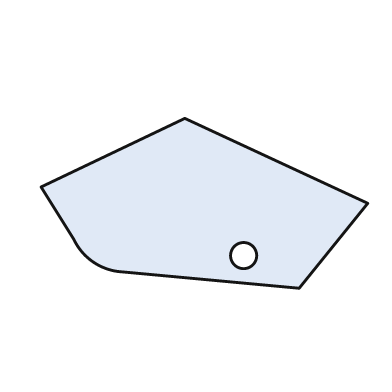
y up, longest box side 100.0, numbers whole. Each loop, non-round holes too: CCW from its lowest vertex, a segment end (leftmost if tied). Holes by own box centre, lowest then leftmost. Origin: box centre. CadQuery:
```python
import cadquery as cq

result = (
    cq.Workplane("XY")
    .moveTo(29.0, -26.0)
    .lineTo(50.0, 0.0)
    .lineTo(-6.0, 26.0)
    .lineTo(-50.0, 5.0)
    .lineTo(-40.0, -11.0)
    .threePointArc((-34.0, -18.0), (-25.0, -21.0))
    .close()
    .moveTo(12.0, -16.0)
    .circle(4.0)
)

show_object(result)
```